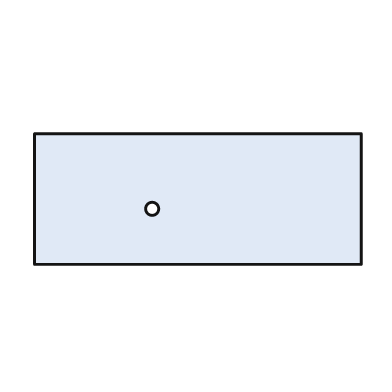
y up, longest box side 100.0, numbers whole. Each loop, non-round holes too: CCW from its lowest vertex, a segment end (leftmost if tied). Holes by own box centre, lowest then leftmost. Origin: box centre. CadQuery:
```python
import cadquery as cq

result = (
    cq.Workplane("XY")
    .moveTo(-50.0, -20.0)
    .lineTo(50.0, -20.0)
    .lineTo(50.0, 20.0)
    .lineTo(-50.0, 20.0)
    .close()
    .moveTo(-14.0, -3.0)
    .circle(2.0)
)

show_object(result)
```